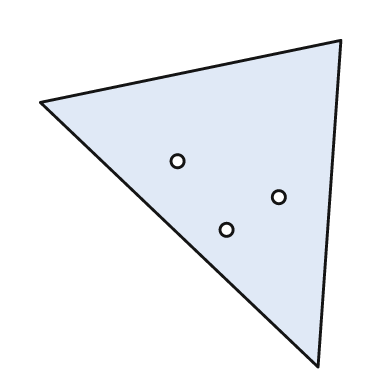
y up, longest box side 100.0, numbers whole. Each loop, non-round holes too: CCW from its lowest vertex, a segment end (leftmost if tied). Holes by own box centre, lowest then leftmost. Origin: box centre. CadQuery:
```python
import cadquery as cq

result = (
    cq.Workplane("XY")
    .moveTo(39.0, -50.0)
    .lineTo(46.0, 50.0)
    .lineTo(-46.0, 31.0)
    .close()
    .moveTo(11.0, -8.0)
    .circle(2.0)
    .moveTo(27.0, 2.0)
    .circle(2.0)
    .moveTo(-4.0, 13.0)
    .circle(2.0)
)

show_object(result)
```